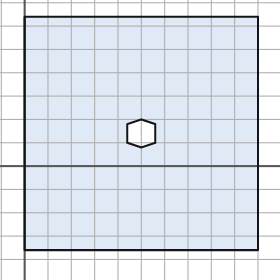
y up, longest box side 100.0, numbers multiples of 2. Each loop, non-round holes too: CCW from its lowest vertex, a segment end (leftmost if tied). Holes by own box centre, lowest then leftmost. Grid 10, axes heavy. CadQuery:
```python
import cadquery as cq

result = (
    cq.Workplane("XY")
    .moveTo(0.0, -36.0)
    .lineTo(100.0, -36.0)
    .lineTo(100.0, 64.0)
    .lineTo(0.0, 64.0)
    .close()
    .moveTo(50.0, 8.0)
    .lineTo(56.0, 10.0)
    .lineTo(56.0, 18.0)
    .lineTo(50.0, 20.0)
    .lineTo(44.0, 18.0)
    .lineTo(44.0, 10.0)
    .close()
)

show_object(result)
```